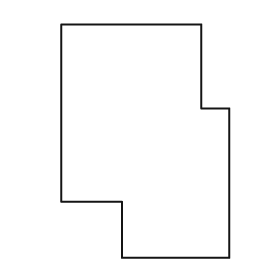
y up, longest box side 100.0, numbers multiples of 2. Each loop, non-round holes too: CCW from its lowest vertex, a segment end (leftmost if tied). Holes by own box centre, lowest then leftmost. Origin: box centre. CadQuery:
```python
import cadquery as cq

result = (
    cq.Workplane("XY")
    .moveTo(-10.0, -50.0)
    .lineTo(36.0, -50.0)
    .lineTo(36.0, 14.0)
    .lineTo(24.0, 14.0)
    .lineTo(24.0, 50.0)
    .lineTo(-36.0, 50.0)
    .lineTo(-36.0, -26.0)
    .lineTo(-10.0, -26.0)
    .close()
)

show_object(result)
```